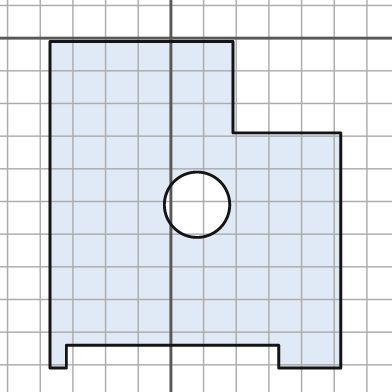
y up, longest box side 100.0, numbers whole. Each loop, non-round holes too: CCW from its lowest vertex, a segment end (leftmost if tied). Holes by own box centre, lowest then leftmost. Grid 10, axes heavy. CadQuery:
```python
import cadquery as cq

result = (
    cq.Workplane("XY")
    .moveTo(-37.0, -101.0)
    .lineTo(-32.0, -101.0)
    .lineTo(-32.0, -94.0)
    .lineTo(33.0, -94.0)
    .lineTo(33.0, -101.0)
    .lineTo(52.0, -101.0)
    .lineTo(52.0, -29.0)
    .lineTo(19.0, -29.0)
    .lineTo(19.0, -1.0)
    .lineTo(-37.0, -1.0)
    .close()
    .moveTo(8.0, -51.0)
    .circle(10.0)
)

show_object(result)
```